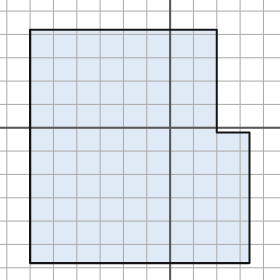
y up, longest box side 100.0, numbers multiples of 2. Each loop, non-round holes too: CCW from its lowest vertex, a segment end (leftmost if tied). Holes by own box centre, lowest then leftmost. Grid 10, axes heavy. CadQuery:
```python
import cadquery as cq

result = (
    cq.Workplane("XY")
    .moveTo(-60.0, -58.0)
    .lineTo(34.0, -58.0)
    .lineTo(34.0, -2.0)
    .lineTo(20.0, -2.0)
    .lineTo(20.0, 42.0)
    .lineTo(-60.0, 42.0)
    .close()
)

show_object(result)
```